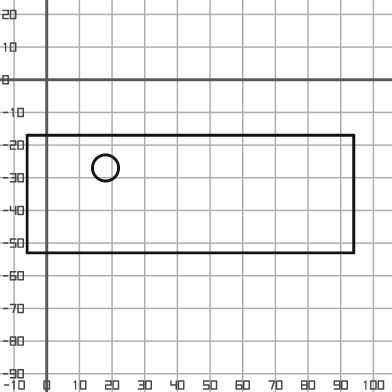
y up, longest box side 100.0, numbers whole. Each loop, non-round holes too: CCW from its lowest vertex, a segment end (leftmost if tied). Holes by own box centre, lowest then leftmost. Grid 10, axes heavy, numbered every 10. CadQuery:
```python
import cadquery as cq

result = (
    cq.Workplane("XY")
    .moveTo(-6.0, -53.0)
    .lineTo(94.0, -53.0)
    .lineTo(94.0, -17.0)
    .lineTo(-6.0, -17.0)
    .close()
    .moveTo(18.0, -27.0)
    .circle(4.0)
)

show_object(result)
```